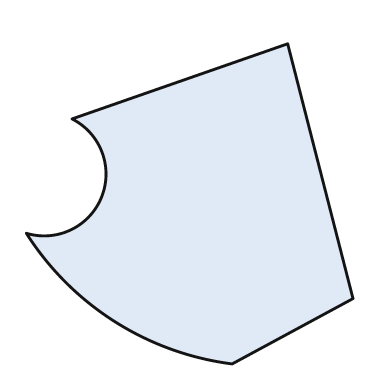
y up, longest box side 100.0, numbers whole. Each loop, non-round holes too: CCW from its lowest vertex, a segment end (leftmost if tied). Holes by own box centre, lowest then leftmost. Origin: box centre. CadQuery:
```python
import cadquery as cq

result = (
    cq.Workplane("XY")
    .moveTo(13.0, -49.0)
    .lineTo(50.0, -29.0)
    .lineTo(30.0, 49.0)
    .lineTo(-36.0, 26.0)
    .threePointArc((-27.0, 2.0), (-50.0, -9.0))
    .threePointArc((-23.0, -36.0), (13.0, -49.0))
    .close()
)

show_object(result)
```